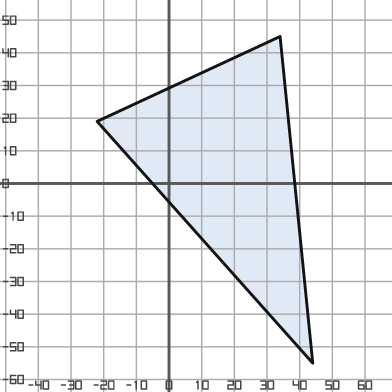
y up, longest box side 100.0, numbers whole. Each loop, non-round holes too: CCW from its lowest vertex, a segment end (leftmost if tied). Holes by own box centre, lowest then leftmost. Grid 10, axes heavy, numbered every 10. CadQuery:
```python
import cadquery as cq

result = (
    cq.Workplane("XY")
    .moveTo(44.0, -55.0)
    .lineTo(34.0, 45.0)
    .lineTo(-22.0, 19.0)
    .close()
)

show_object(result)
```